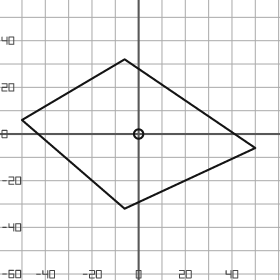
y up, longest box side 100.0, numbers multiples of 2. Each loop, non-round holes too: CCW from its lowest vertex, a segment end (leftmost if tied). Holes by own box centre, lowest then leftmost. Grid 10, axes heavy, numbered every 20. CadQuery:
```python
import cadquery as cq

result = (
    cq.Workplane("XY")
    .moveTo(-6.0, -32.0)
    .lineTo(50.0, -6.0)
    .lineTo(-6.0, 32.0)
    .lineTo(-50.0, 6.0)
    .close()
    .moveTo(0.0, 0.0)
    .circle(2.0)
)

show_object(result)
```